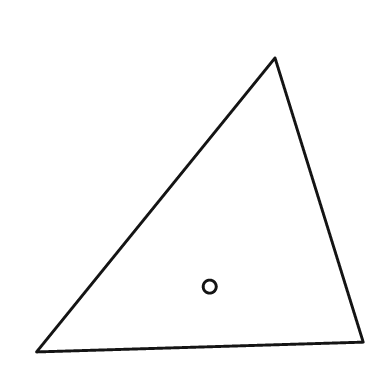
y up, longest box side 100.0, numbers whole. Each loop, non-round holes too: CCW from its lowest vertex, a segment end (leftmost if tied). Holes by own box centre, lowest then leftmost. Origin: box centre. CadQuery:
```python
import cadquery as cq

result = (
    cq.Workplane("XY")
    .moveTo(-50.0, -45.0)
    .lineTo(50.0, -42.0)
    .lineTo(23.0, 45.0)
    .close()
    .moveTo(3.0, -25.0)
    .circle(2.0)
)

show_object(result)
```